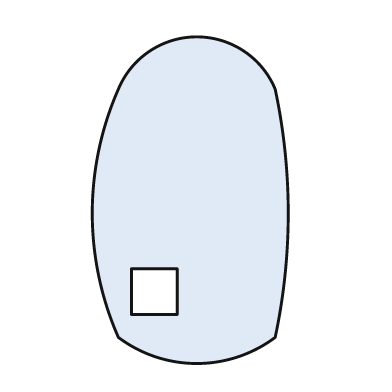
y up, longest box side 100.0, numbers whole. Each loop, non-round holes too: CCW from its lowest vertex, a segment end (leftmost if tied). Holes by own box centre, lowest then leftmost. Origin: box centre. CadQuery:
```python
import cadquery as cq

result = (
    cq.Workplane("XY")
    .moveTo(-22.0, -42.0)
    .threePointArc((2.0, -50.0), (26.0, -42.0))
    .threePointArc((30.0, -4.0), (26.0, 34.0))
    .threePointArc((2.0, 50.0), (-22.0, 34.0))
    .threePointArc((-30.0, -4.0), (-22.0, -42.0))
    .close()
    .moveTo(-18.0, -35.0)
    .lineTo(-4.0, -35.0)
    .lineTo(-4.0, -21.0)
    .lineTo(-18.0, -21.0)
    .close()
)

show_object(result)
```